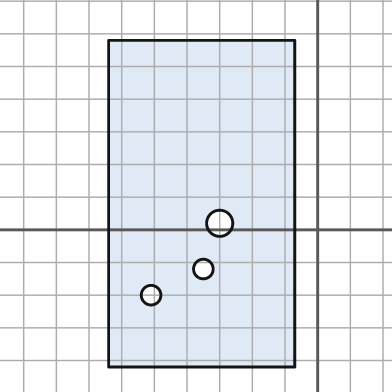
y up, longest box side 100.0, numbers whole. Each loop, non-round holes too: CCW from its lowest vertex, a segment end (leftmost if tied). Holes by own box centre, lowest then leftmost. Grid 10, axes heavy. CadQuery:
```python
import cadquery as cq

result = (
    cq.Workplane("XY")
    .moveTo(-64.0, -42.0)
    .lineTo(-7.0, -42.0)
    .lineTo(-7.0, 58.0)
    .lineTo(-64.0, 58.0)
    .close()
    .moveTo(-51.0, -20.0)
    .circle(3.0)
    .moveTo(-35.0, -12.0)
    .circle(3.0)
    .moveTo(-30.0, 2.0)
    .circle(4.0)
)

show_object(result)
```